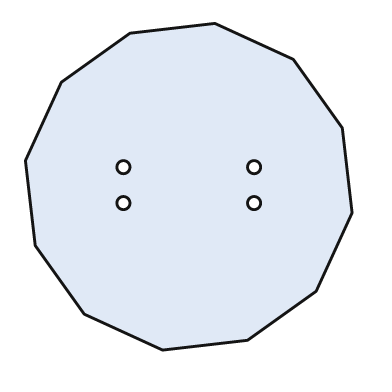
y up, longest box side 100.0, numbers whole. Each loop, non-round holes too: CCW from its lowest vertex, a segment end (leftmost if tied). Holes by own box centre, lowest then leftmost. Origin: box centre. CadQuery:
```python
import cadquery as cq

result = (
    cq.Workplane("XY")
    .moveTo(-8.0, -50.0)
    .lineTo(18.0, -47.0)
    .lineTo(39.0, -32.0)
    .lineTo(50.0, -8.0)
    .lineTo(47.0, 18.0)
    .lineTo(32.0, 39.0)
    .lineTo(8.0, 50.0)
    .lineTo(-18.0, 47.0)
    .lineTo(-39.0, 32.0)
    .lineTo(-50.0, 8.0)
    .lineTo(-47.0, -18.0)
    .lineTo(-32.0, -39.0)
    .close()
    .moveTo(-20.0, -5.0)
    .circle(2.0)
    .moveTo(20.0, -5.0)
    .circle(2.0)
    .moveTo(-20.0, 6.0)
    .circle(2.0)
    .moveTo(20.0, 6.0)
    .circle(2.0)
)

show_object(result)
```